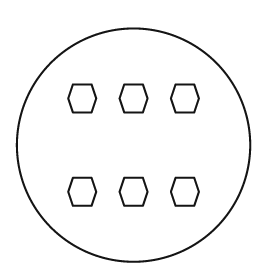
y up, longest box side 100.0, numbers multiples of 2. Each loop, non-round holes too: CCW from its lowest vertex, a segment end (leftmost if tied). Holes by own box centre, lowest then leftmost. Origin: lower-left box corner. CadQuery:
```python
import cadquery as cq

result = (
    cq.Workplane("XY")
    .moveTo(50.0, 50.0)
    .circle(50.0)
    .moveTo(24.0, 24.0)
    .lineTo(32.0, 24.0)
    .lineTo(34.0, 30.0)
    .lineTo(32.0, 36.0)
    .lineTo(24.0, 36.0)
    .lineTo(22.0, 30.0)
    .close()
    .moveTo(46.0, 24.0)
    .lineTo(54.0, 24.0)
    .lineTo(56.0, 30.0)
    .lineTo(54.0, 36.0)
    .lineTo(46.0, 36.0)
    .lineTo(44.0, 30.0)
    .close()
    .moveTo(68.0, 24.0)
    .lineTo(76.0, 24.0)
    .lineTo(78.0, 30.0)
    .lineTo(76.0, 36.0)
    .lineTo(68.0, 36.0)
    .lineTo(66.0, 30.0)
    .close()
    .moveTo(24.0, 64.0)
    .lineTo(32.0, 64.0)
    .lineTo(34.0, 70.0)
    .lineTo(32.0, 76.0)
    .lineTo(24.0, 76.0)
    .lineTo(22.0, 70.0)
    .close()
    .moveTo(46.0, 64.0)
    .lineTo(54.0, 64.0)
    .lineTo(56.0, 70.0)
    .lineTo(54.0, 76.0)
    .lineTo(46.0, 76.0)
    .lineTo(44.0, 70.0)
    .close()
    .moveTo(68.0, 64.0)
    .lineTo(76.0, 64.0)
    .lineTo(78.0, 70.0)
    .lineTo(76.0, 76.0)
    .lineTo(68.0, 76.0)
    .lineTo(66.0, 70.0)
    .close()
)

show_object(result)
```